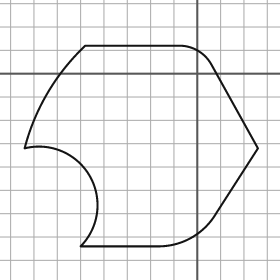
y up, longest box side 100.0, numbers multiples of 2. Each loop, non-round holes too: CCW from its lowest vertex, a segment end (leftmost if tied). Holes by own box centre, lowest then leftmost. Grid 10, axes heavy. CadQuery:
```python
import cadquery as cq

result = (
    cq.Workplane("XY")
    .moveTo(-50.0, -74.0)
    .lineTo(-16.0, -74.0)
    .threePointArc((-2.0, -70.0), (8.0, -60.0))
    .lineTo(26.0, -32.0)
    .lineTo(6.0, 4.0)
    .threePointArc((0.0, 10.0), (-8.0, 12.0))
    .lineTo(-48.0, 12.0)
    .threePointArc((-64.0, -8.0), (-74.0, -32.0))
    .threePointArc((-46.0, -44.0), (-50.0, -74.0))
    .close()
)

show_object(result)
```